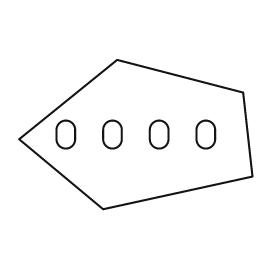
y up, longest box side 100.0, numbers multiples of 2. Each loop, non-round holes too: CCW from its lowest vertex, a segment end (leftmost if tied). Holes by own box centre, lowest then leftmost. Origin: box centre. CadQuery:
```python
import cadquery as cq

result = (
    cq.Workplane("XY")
    .moveTo(-14.0, -32.0)
    .lineTo(50.0, -18.0)
    .lineTo(46.0, 18.0)
    .lineTo(-8.0, 32.0)
    .lineTo(-50.0, -2.0)
    .close()
    .moveTo(-34.0, -2.0)
    .threePointArc((-30.0, -6.0), (-26.0, -2.0))
    .lineTo(-26.0, 2.0)
    .threePointArc((-30.0, 6.0), (-34.0, 2.0))
    .close()
    .moveTo(-14.0, -2.0)
    .threePointArc((-10.0, -6.0), (-6.0, -2.0))
    .lineTo(-6.0, 2.0)
    .threePointArc((-10.0, 6.0), (-14.0, 2.0))
    .close()
    .moveTo(6.0, -2.0)
    .threePointArc((10.0, -6.0), (14.0, -2.0))
    .lineTo(14.0, 2.0)
    .threePointArc((10.0, 6.0), (6.0, 2.0))
    .close()
    .moveTo(26.0, -2.0)
    .threePointArc((30.0, -6.0), (34.0, -2.0))
    .lineTo(34.0, 2.0)
    .threePointArc((30.0, 6.0), (26.0, 2.0))
    .close()
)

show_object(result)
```